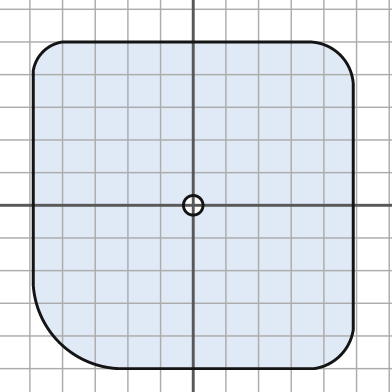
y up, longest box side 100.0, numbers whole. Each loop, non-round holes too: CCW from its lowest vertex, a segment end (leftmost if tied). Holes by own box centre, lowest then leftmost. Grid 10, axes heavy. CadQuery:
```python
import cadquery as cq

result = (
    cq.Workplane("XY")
    .moveTo(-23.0, -50.0)
    .lineTo(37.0, -50.0)
    .threePointArc((45.0, -46.0), (49.0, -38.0))
    .lineTo(49.0, 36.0)
    .threePointArc((45.0, 46.0), (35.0, 50.0))
    .lineTo(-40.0, 50.0)
    .threePointArc((-46.0, 47.0), (-49.0, 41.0))
    .lineTo(-49.0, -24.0)
    .threePointArc((-41.0, -42.0), (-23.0, -50.0))
    .close()
    .moveTo(0.0, 0.0)
    .circle(3.0)
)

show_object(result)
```